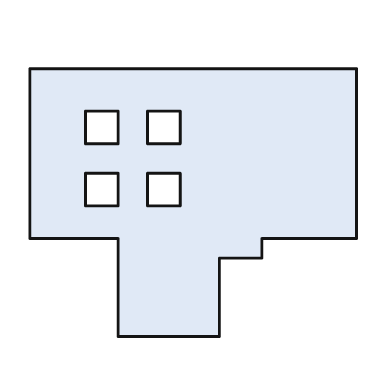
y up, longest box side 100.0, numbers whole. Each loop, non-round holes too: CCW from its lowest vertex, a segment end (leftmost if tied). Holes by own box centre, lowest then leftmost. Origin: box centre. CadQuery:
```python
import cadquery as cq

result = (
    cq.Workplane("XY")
    .moveTo(-23.0, -41.0)
    .lineTo(8.0, -41.0)
    .lineTo(8.0, -17.0)
    .lineTo(21.0, -17.0)
    .lineTo(21.0, -11.0)
    .lineTo(50.0, -11.0)
    .lineTo(50.0, 41.0)
    .lineTo(-50.0, 41.0)
    .lineTo(-50.0, -11.0)
    .lineTo(-23.0, -11.0)
    .close()
    .moveTo(-33.0, -1.0)
    .lineTo(-23.0, -1.0)
    .lineTo(-23.0, 9.0)
    .lineTo(-33.0, 9.0)
    .close()
    .moveTo(-14.0, -1.0)
    .lineTo(-4.0, -1.0)
    .lineTo(-4.0, 9.0)
    .lineTo(-14.0, 9.0)
    .close()
    .moveTo(-33.0, 18.0)
    .lineTo(-23.0, 18.0)
    .lineTo(-23.0, 28.0)
    .lineTo(-33.0, 28.0)
    .close()
    .moveTo(-14.0, 18.0)
    .lineTo(-4.0, 18.0)
    .lineTo(-4.0, 28.0)
    .lineTo(-14.0, 28.0)
    .close()
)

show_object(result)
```